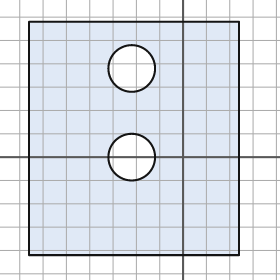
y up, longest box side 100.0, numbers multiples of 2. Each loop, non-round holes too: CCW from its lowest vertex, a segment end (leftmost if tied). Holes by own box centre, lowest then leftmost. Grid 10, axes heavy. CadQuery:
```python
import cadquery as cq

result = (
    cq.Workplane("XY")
    .moveTo(-66.0, -42.0)
    .lineTo(24.0, -42.0)
    .lineTo(24.0, 58.0)
    .lineTo(-66.0, 58.0)
    .close()
    .moveTo(-22.0, 0.0)
    .circle(10.0)
    .moveTo(-22.0, 38.0)
    .circle(10.0)
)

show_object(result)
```